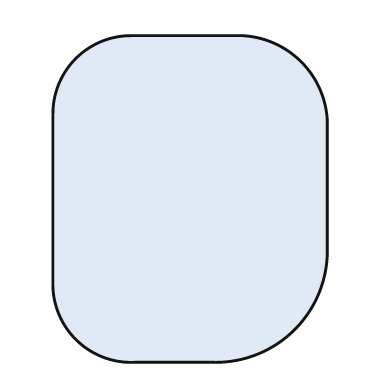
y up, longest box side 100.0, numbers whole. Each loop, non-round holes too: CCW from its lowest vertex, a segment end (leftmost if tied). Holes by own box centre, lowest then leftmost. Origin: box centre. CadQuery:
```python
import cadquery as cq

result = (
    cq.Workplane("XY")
    .moveTo(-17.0, -50.0)
    .lineTo(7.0, -50.0)
    .threePointArc((32.0, -40.0), (42.0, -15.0))
    .lineTo(42.0, 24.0)
    .threePointArc((34.0, 42.0), (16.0, 50.0))
    .lineTo(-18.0, 50.0)
    .threePointArc((-35.0, 43.0), (-42.0, 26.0))
    .lineTo(-42.0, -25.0)
    .threePointArc((-35.0, -43.0), (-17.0, -50.0))
    .close()
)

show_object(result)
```